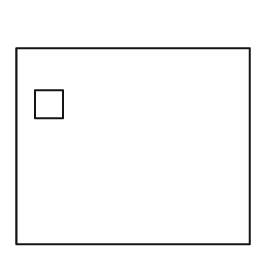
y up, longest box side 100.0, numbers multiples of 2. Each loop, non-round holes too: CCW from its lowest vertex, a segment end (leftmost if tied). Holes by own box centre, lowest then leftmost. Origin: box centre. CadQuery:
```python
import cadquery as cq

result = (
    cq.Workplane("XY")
    .moveTo(-50.0, -42.0)
    .lineTo(50.0, -42.0)
    .lineTo(50.0, 42.0)
    .lineTo(-50.0, 42.0)
    .close()
    .moveTo(-42.0, 12.0)
    .lineTo(-30.0, 12.0)
    .lineTo(-30.0, 24.0)
    .lineTo(-42.0, 24.0)
    .close()
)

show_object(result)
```